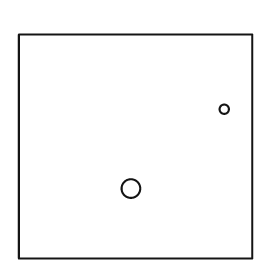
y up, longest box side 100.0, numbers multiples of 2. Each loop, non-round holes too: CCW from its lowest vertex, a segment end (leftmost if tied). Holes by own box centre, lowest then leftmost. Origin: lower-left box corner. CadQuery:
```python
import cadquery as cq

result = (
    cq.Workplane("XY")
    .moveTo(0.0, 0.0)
    .lineTo(100.0, 0.0)
    .lineTo(100.0, 96.0)
    .lineTo(0.0, 96.0)
    .close()
    .moveTo(48.0, 30.0)
    .circle(4.0)
    .moveTo(88.0, 64.0)
    .circle(2.0)
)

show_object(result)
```